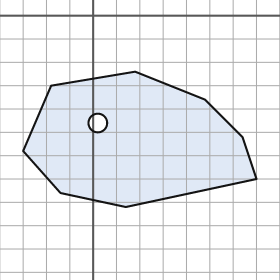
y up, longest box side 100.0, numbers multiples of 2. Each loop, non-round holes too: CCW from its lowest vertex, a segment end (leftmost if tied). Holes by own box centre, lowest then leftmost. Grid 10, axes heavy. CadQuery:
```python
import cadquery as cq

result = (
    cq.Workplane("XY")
    .moveTo(14.0, -82.0)
    .lineTo(70.0, -70.0)
    .lineTo(64.0, -52.0)
    .lineTo(48.0, -36.0)
    .lineTo(18.0, -24.0)
    .lineTo(-18.0, -30.0)
    .lineTo(-30.0, -58.0)
    .lineTo(-14.0, -76.0)
    .close()
    .moveTo(2.0, -46.0)
    .circle(4.0)
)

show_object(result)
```